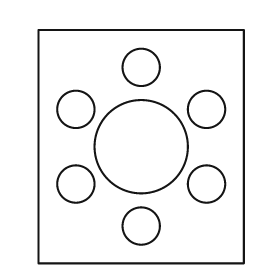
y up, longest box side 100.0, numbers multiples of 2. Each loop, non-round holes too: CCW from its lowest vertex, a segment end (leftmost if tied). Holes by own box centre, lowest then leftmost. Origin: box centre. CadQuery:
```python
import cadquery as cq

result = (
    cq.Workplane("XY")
    .moveTo(-44.0, -50.0)
    .lineTo(44.0, -50.0)
    .lineTo(44.0, 50.0)
    .lineTo(-44.0, 50.0)
    .close()
    .moveTo(0.0, -34.0)
    .circle(8.0)
    .moveTo(-28.0, -16.0)
    .circle(8.0)
    .moveTo(28.0, -16.0)
    .circle(8.0)
    .moveTo(0.0, 0.0)
    .circle(20.0)
    .moveTo(-28.0, 16.0)
    .circle(8.0)
    .moveTo(28.0, 16.0)
    .circle(8.0)
    .moveTo(0.0, 34.0)
    .circle(8.0)
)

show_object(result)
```